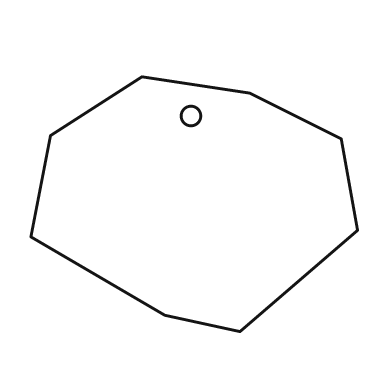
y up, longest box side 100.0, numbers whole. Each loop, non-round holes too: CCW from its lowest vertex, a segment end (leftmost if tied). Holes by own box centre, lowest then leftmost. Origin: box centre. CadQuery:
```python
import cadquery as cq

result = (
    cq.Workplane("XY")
    .moveTo(14.0, -39.0)
    .lineTo(50.0, -8.0)
    .lineTo(45.0, 20.0)
    .lineTo(17.0, 34.0)
    .lineTo(-16.0, 39.0)
    .lineTo(-44.0, 21.0)
    .lineTo(-50.0, -10.0)
    .lineTo(-9.0, -34.0)
    .close()
    .moveTo(-1.0, 27.0)
    .circle(3.0)
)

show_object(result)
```